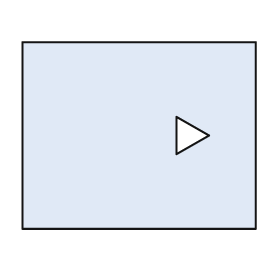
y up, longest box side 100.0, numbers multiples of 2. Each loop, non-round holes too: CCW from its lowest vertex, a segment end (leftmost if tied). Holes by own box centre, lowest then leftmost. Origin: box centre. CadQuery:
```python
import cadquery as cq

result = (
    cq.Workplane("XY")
    .moveTo(-50.0, -40.0)
    .lineTo(50.0, -40.0)
    .lineTo(50.0, 40.0)
    .lineTo(-50.0, 40.0)
    .close()
    .moveTo(16.0, -8.0)
    .lineTo(30.0, 0.0)
    .lineTo(16.0, 8.0)
    .close()
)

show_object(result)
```